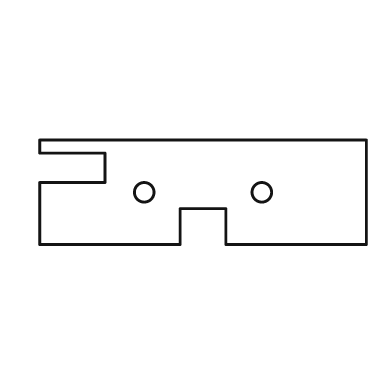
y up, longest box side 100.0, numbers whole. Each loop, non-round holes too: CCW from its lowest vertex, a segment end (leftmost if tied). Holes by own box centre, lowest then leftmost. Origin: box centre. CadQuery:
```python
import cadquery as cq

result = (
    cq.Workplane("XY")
    .moveTo(-50.0, -16.0)
    .lineTo(-7.0, -16.0)
    .lineTo(-7.0, -5.0)
    .lineTo(7.0, -5.0)
    .lineTo(7.0, -16.0)
    .lineTo(50.0, -16.0)
    .lineTo(50.0, 16.0)
    .lineTo(-50.0, 16.0)
    .lineTo(-50.0, 12.0)
    .lineTo(-30.0, 12.0)
    .lineTo(-30.0, 3.0)
    .lineTo(-50.0, 3.0)
    .close()
    .moveTo(-18.0, 0.0)
    .circle(3.0)
    .moveTo(18.0, 0.0)
    .circle(3.0)
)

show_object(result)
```